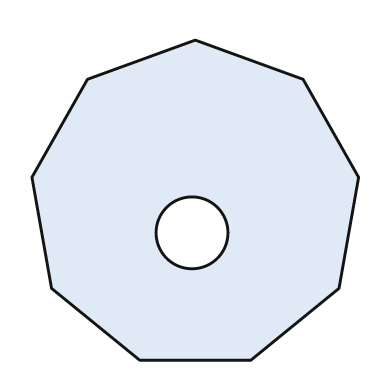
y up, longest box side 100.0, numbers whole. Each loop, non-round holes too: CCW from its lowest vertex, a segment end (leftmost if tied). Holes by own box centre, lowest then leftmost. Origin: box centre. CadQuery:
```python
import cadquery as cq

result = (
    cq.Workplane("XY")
    .moveTo(-17.0, -49.0)
    .lineTo(17.0, -49.0)
    .lineTo(44.0, -27.0)
    .lineTo(50.0, 7.0)
    .lineTo(33.0, 37.0)
    .lineTo(0.0, 49.0)
    .lineTo(-33.0, 37.0)
    .lineTo(-50.0, 7.0)
    .lineTo(-44.0, -27.0)
    .close()
    .moveTo(-1.0, -10.0)
    .circle(11.0)
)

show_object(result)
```